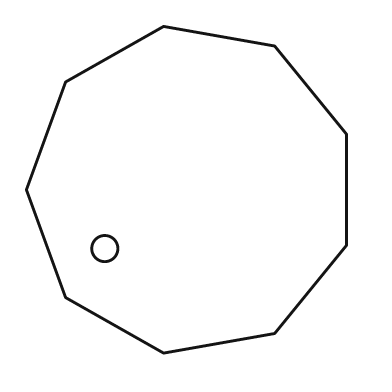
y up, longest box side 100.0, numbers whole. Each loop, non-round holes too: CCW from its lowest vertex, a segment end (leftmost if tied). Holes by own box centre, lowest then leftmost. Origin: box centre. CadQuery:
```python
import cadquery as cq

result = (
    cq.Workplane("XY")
    .moveTo(-7.0, -50.0)
    .lineTo(27.0, -44.0)
    .lineTo(49.0, -17.0)
    .lineTo(49.0, 17.0)
    .lineTo(27.0, 44.0)
    .lineTo(-7.0, 50.0)
    .lineTo(-37.0, 33.0)
    .lineTo(-49.0, 0.0)
    .lineTo(-37.0, -33.0)
    .close()
    .moveTo(-25.0, -18.0)
    .circle(4.0)
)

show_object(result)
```